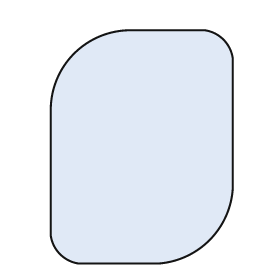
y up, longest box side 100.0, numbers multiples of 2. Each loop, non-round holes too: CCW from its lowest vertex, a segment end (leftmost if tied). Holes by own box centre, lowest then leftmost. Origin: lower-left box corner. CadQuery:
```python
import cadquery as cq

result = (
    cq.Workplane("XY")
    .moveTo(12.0, 0.0)
    .lineTo(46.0, 0.0)
    .threePointArc((68.0, 10.0), (78.0, 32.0))
    .lineTo(78.0, 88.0)
    .threePointArc((74.0, 96.0), (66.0, 100.0))
    .lineTo(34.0, 100.0)
    .threePointArc((10.0, 90.0), (0.0, 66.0))
    .lineTo(0.0, 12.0)
    .threePointArc((4.0, 4.0), (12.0, 0.0))
    .close()
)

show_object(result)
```